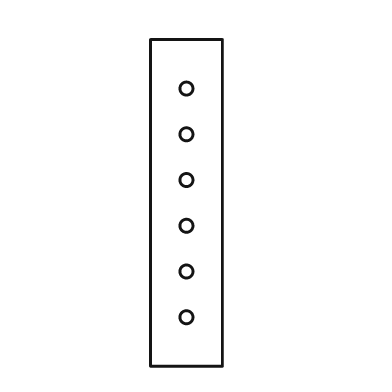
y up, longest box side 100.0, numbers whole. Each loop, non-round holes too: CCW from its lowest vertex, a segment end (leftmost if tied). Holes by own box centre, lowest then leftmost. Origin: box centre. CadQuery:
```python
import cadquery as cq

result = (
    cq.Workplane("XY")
    .moveTo(-11.0, -50.0)
    .lineTo(11.0, -50.0)
    .lineTo(11.0, 50.0)
    .lineTo(-11.0, 50.0)
    .close()
    .moveTo(0.0, -35.0)
    .circle(2.0)
    .moveTo(0.0, -21.0)
    .circle(2.0)
    .moveTo(0.0, -7.0)
    .circle(2.0)
    .moveTo(0.0, 7.0)
    .circle(2.0)
    .moveTo(0.0, 21.0)
    .circle(2.0)
    .moveTo(0.0, 35.0)
    .circle(2.0)
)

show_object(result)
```